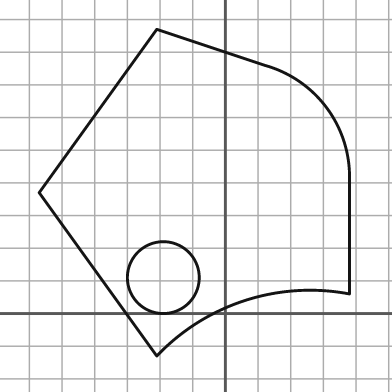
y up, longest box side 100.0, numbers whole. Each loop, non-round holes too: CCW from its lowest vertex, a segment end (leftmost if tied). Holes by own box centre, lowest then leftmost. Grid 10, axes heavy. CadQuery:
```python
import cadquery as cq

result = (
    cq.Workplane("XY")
    .moveTo(-21.0, -13.0)
    .threePointArc((6.0, 4.0), (38.0, 6.0))
    .lineTo(38.0, 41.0)
    .threePointArc((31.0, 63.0), (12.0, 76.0))
    .lineTo(-21.0, 87.0)
    .lineTo(-57.0, 37.0)
    .close()
    .moveTo(-19.0, 11.0)
    .circle(11.0)
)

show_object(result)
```